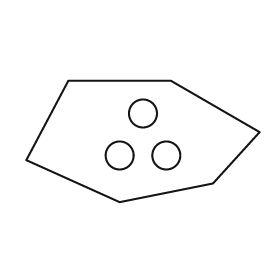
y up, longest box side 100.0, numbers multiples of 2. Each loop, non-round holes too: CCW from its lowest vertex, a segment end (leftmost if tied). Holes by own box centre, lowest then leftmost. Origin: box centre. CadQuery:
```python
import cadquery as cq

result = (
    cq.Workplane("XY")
    .moveTo(-10.0, -26.0)
    .lineTo(30.0, -18.0)
    .lineTo(50.0, 4.0)
    .lineTo(12.0, 26.0)
    .lineTo(-32.0, 26.0)
    .lineTo(-50.0, -8.0)
    .close()
    .moveTo(-10.0, -6.0)
    .circle(6.0)
    .moveTo(10.0, -6.0)
    .circle(6.0)
    .moveTo(0.0, 12.0)
    .circle(6.0)
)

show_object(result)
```